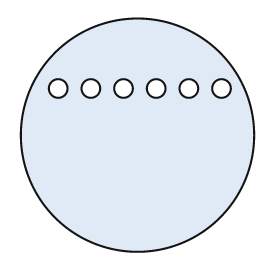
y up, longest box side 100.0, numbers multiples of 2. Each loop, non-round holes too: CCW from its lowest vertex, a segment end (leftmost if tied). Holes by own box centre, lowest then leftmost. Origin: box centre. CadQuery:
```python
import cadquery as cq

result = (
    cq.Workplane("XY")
    .moveTo(0.0, 0.0)
    .circle(50.0)
    .moveTo(-34.0, 20.0)
    .circle(4.0)
    .moveTo(-20.0, 20.0)
    .circle(4.0)
    .moveTo(-6.0, 20.0)
    .circle(4.0)
    .moveTo(8.0, 20.0)
    .circle(4.0)
    .moveTo(22.0, 20.0)
    .circle(4.0)
    .moveTo(36.0, 20.0)
    .circle(4.0)
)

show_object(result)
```